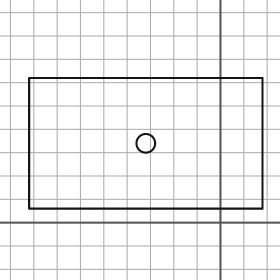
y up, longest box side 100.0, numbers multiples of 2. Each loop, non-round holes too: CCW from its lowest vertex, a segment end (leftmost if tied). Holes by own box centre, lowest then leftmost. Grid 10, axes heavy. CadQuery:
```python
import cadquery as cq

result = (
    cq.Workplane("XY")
    .moveTo(-82.0, 6.0)
    .lineTo(18.0, 6.0)
    .lineTo(18.0, 62.0)
    .lineTo(-82.0, 62.0)
    .close()
    .moveTo(-32.0, 34.0)
    .circle(4.0)
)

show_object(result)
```